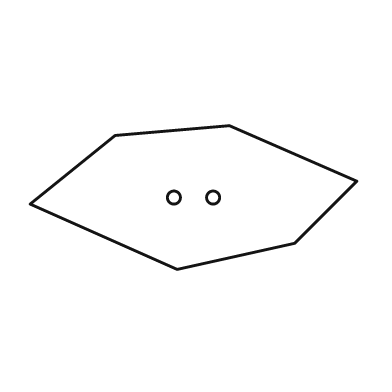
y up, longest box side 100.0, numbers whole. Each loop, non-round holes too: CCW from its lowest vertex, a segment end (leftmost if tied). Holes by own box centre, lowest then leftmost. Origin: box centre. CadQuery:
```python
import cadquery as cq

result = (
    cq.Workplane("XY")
    .moveTo(-5.0, -22.0)
    .lineTo(31.0, -14.0)
    .lineTo(50.0, 5.0)
    .lineTo(11.0, 22.0)
    .lineTo(-24.0, 19.0)
    .lineTo(-50.0, -2.0)
    .close()
    .moveTo(-6.0, 0.0)
    .circle(2.0)
    .moveTo(6.0, 0.0)
    .circle(2.0)
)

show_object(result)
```